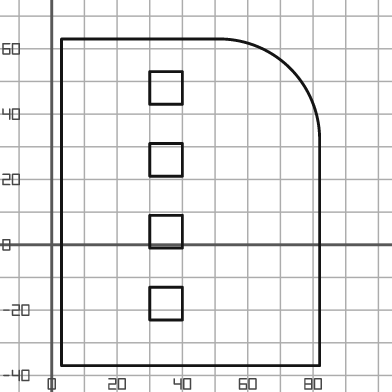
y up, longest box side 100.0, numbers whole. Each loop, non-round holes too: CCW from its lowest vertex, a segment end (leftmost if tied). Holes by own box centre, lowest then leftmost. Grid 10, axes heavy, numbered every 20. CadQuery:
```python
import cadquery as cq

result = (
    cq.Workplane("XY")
    .moveTo(3.0, -37.0)
    .lineTo(82.0, -37.0)
    .lineTo(82.0, 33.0)
    .threePointArc((73.0, 54.0), (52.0, 63.0))
    .lineTo(3.0, 63.0)
    .close()
    .moveTo(30.0, -23.0)
    .lineTo(40.0, -23.0)
    .lineTo(40.0, -13.0)
    .lineTo(30.0, -13.0)
    .close()
    .moveTo(30.0, -1.0)
    .lineTo(40.0, -1.0)
    .lineTo(40.0, 9.0)
    .lineTo(30.0, 9.0)
    .close()
    .moveTo(30.0, 21.0)
    .lineTo(40.0, 21.0)
    .lineTo(40.0, 31.0)
    .lineTo(30.0, 31.0)
    .close()
    .moveTo(30.0, 43.0)
    .lineTo(40.0, 43.0)
    .lineTo(40.0, 53.0)
    .lineTo(30.0, 53.0)
    .close()
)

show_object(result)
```